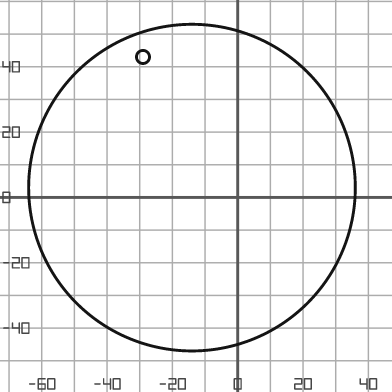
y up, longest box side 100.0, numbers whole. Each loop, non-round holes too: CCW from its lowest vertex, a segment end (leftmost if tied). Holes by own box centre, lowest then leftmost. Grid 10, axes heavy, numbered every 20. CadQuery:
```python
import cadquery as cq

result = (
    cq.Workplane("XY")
    .moveTo(-14.0, 3.0)
    .circle(50.0)
    .moveTo(-29.0, 43.0)
    .circle(2.0)
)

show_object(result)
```